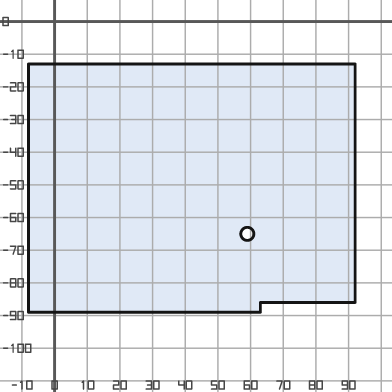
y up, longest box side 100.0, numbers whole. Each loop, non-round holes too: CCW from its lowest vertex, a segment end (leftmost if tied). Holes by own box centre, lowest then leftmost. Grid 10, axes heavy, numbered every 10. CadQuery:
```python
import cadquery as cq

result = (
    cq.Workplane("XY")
    .moveTo(-8.0, -89.0)
    .lineTo(63.0, -89.0)
    .lineTo(63.0, -86.0)
    .lineTo(92.0, -86.0)
    .lineTo(92.0, -13.0)
    .lineTo(-8.0, -13.0)
    .close()
    .moveTo(59.0, -65.0)
    .circle(2.0)
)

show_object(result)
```